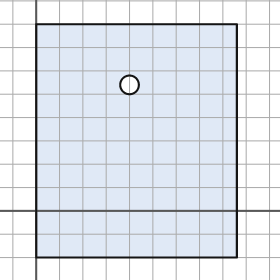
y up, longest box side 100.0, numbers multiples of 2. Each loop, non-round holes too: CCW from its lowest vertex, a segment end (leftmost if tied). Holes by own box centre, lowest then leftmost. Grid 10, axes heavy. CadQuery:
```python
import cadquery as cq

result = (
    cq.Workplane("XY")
    .moveTo(0.0, -20.0)
    .lineTo(86.0, -20.0)
    .lineTo(86.0, 80.0)
    .lineTo(0.0, 80.0)
    .close()
    .moveTo(40.0, 54.0)
    .circle(4.0)
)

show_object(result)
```